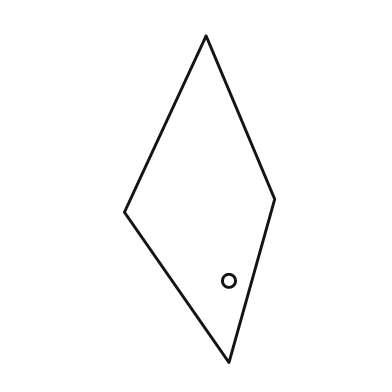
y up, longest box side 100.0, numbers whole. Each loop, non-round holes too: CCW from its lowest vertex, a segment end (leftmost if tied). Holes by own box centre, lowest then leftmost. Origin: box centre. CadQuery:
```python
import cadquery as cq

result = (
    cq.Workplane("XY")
    .moveTo(9.0, -50.0)
    .lineTo(23.0, 0.0)
    .lineTo(2.0, 50.0)
    .lineTo(-23.0, -4.0)
    .close()
    .moveTo(9.0, -25.0)
    .circle(2.0)
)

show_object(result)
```